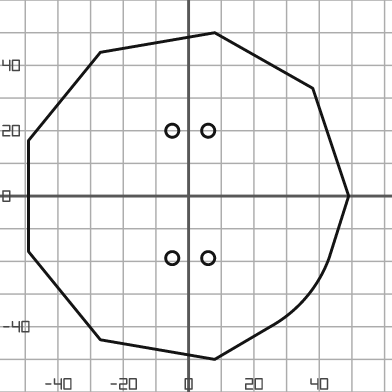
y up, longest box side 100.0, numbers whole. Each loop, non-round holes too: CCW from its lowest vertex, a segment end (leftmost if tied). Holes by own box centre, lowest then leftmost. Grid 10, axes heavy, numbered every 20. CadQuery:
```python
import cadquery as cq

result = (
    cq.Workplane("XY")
    .moveTo(8.0, -50.0)
    .lineTo(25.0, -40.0)
    .threePointArc((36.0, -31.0), (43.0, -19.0))
    .lineTo(49.0, 0.0)
    .lineTo(38.0, 33.0)
    .lineTo(8.0, 50.0)
    .lineTo(-27.0, 44.0)
    .lineTo(-49.0, 17.0)
    .lineTo(-49.0, -17.0)
    .lineTo(-27.0, -44.0)
    .close()
    .moveTo(-5.0, -19.0)
    .circle(2.0)
    .moveTo(6.0, -19.0)
    .circle(2.0)
    .moveTo(-5.0, 20.0)
    .circle(2.0)
    .moveTo(6.0, 20.0)
    .circle(2.0)
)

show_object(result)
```